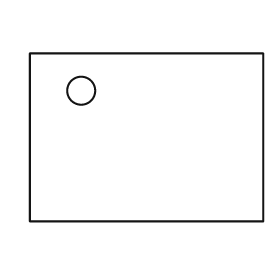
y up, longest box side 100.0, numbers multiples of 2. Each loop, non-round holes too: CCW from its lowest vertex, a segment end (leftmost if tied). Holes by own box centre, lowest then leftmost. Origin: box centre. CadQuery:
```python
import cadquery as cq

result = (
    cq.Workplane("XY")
    .moveTo(-50.0, -36.0)
    .lineTo(50.0, -36.0)
    .lineTo(50.0, 36.0)
    .lineTo(-50.0, 36.0)
    .close()
    .moveTo(-28.0, 20.0)
    .circle(6.0)
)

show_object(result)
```